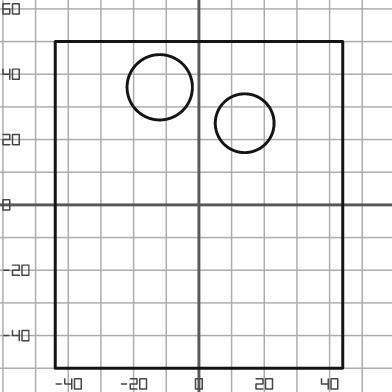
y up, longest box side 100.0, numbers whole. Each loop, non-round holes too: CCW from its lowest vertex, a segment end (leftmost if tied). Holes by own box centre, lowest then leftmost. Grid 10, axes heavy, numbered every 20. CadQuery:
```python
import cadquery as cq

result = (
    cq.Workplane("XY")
    .moveTo(-44.0, -50.0)
    .lineTo(44.0, -50.0)
    .lineTo(44.0, 50.0)
    .lineTo(-44.0, 50.0)
    .close()
    .moveTo(14.0, 25.0)
    .circle(9.0)
    .moveTo(-12.0, 36.0)
    .circle(10.0)
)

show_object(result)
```